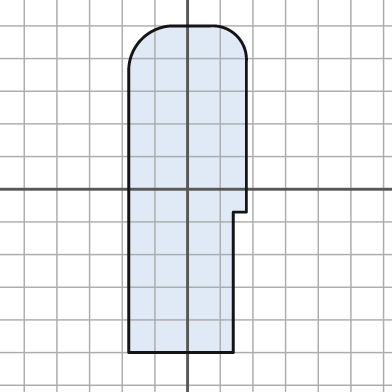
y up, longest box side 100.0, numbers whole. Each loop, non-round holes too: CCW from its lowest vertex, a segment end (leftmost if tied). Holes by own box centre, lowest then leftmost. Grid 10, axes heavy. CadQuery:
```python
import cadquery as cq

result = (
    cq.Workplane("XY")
    .moveTo(-18.0, -50.0)
    .lineTo(14.0, -50.0)
    .lineTo(14.0, -7.0)
    .lineTo(18.0, -7.0)
    .lineTo(18.0, 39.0)
    .threePointArc((15.0, 47.0), (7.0, 50.0))
    .lineTo(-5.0, 50.0)
    .threePointArc((-14.0, 46.0), (-18.0, 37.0))
    .close()
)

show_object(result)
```